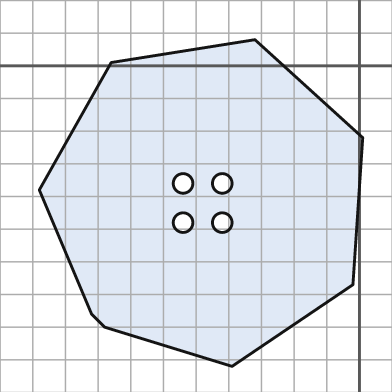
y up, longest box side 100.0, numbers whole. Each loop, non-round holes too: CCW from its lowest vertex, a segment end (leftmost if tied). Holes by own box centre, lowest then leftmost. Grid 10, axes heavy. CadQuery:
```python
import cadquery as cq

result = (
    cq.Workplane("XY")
    .moveTo(-39.0, -92.0)
    .lineTo(-2.0, -67.0)
    .lineTo(1.0, -22.0)
    .lineTo(-32.0, 8.0)
    .lineTo(-76.0, 1.0)
    .lineTo(-98.0, -38.0)
    .lineTo(-82.0, -76.0)
    .lineTo(-78.0, -80.0)
    .close()
    .moveTo(-54.0, -48.0)
    .circle(3.0)
    .moveTo(-42.0, -48.0)
    .circle(3.0)
    .moveTo(-54.0, -36.0)
    .circle(3.0)
    .moveTo(-42.0, -36.0)
    .circle(3.0)
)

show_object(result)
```